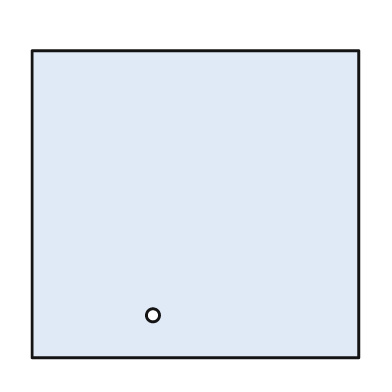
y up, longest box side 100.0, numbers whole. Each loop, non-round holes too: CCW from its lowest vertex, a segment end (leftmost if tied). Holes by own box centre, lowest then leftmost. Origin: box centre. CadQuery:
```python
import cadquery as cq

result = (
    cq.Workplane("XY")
    .moveTo(-50.0, -47.0)
    .lineTo(50.0, -47.0)
    .lineTo(50.0, 47.0)
    .lineTo(-50.0, 47.0)
    .close()
    .moveTo(-13.0, -34.0)
    .circle(2.0)
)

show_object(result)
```